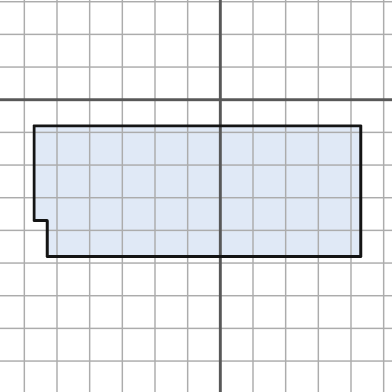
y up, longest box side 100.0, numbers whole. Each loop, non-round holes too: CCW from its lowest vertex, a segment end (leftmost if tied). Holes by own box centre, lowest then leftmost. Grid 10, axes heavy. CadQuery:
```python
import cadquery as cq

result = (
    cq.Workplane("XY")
    .moveTo(-53.0, -48.0)
    .lineTo(43.0, -48.0)
    .lineTo(43.0, -8.0)
    .lineTo(-57.0, -8.0)
    .lineTo(-57.0, -37.0)
    .lineTo(-53.0, -37.0)
    .close()
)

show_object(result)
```